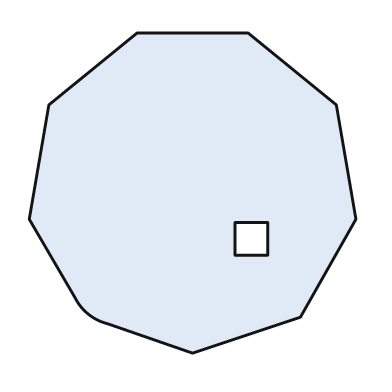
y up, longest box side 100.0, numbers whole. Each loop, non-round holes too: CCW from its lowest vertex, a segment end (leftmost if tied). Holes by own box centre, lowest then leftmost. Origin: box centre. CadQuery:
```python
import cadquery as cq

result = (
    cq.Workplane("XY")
    .moveTo(0.0, -49.0)
    .lineTo(33.0, -38.0)
    .lineTo(50.0, -8.0)
    .lineTo(44.0, 27.0)
    .lineTo(17.0, 49.0)
    .lineTo(-17.0, 49.0)
    .lineTo(-44.0, 27.0)
    .lineTo(-50.0, -8.0)
    .lineTo(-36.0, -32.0)
    .threePointArc((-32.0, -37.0), (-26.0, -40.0))
    .close()
    .moveTo(13.0, -19.0)
    .lineTo(23.0, -19.0)
    .lineTo(23.0, -9.0)
    .lineTo(13.0, -9.0)
    .close()
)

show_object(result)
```